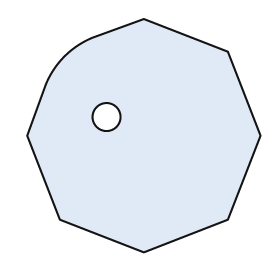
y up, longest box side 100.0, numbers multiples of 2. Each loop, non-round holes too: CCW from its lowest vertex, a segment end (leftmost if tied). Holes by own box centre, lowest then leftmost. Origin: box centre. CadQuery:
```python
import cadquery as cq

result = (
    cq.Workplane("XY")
    .moveTo(0.0, -50.0)
    .lineTo(36.0, -36.0)
    .lineTo(50.0, 0.0)
    .lineTo(36.0, 36.0)
    .lineTo(0.0, 50.0)
    .lineTo(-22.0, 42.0)
    .threePointArc((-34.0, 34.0), (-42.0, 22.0))
    .lineTo(-50.0, 0.0)
    .lineTo(-36.0, -36.0)
    .close()
    .moveTo(-16.0, 8.0)
    .circle(6.0)
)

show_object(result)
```